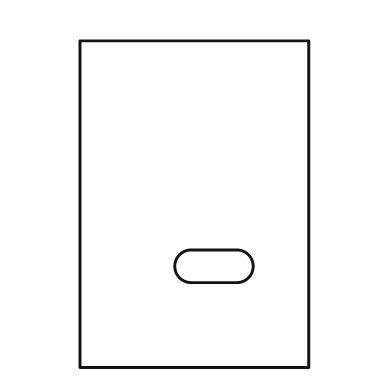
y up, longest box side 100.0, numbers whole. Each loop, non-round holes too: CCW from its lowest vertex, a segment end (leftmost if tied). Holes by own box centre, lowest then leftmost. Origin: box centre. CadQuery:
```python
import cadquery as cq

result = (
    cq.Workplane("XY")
    .moveTo(-35.0, -50.0)
    .lineTo(35.0, -50.0)
    .lineTo(35.0, 50.0)
    .lineTo(-35.0, 50.0)
    .close()
    .moveTo(-1.0, -24.0)
    .lineTo(13.0, -24.0)
    .threePointArc((18.0, -19.0), (13.0, -14.0))
    .lineTo(-1.0, -14.0)
    .threePointArc((-6.0, -19.0), (-1.0, -24.0))
    .close()
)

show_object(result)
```